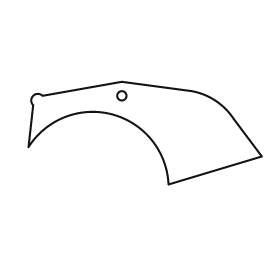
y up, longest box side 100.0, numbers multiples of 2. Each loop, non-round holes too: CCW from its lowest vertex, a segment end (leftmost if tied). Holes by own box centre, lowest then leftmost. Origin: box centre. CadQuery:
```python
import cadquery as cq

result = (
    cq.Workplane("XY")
    .moveTo(10.0, -22.0)
    .lineTo(50.0, -10.0)
    .lineTo(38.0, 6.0)
    .threePointArc((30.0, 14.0), (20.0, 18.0))
    .lineTo(-10.0, 22.0)
    .lineTo(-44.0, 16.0)
    .threePointArc((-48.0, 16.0), (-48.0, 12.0))
    .lineTo(-50.0, -6.0)
    .threePointArc((-14.0, 8.0), (10.0, -22.0))
    .close()
    .moveTo(-10.0, 16.0)
    .circle(2.0)
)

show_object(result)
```